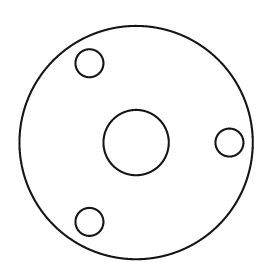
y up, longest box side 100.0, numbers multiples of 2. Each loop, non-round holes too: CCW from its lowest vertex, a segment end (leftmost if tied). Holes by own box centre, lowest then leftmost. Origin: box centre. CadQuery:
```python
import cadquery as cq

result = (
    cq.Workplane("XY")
    .moveTo(0.0, 0.0)
    .circle(50.0)
    .moveTo(-20.0, -34.0)
    .circle(6.0)
    .moveTo(0.0, 0.0)
    .circle(14.0)
    .moveTo(40.0, 0.0)
    .circle(6.0)
    .moveTo(-20.0, 34.0)
    .circle(6.0)
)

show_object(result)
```